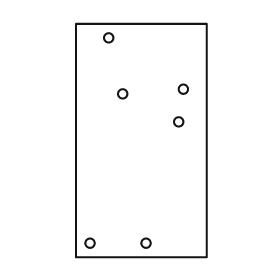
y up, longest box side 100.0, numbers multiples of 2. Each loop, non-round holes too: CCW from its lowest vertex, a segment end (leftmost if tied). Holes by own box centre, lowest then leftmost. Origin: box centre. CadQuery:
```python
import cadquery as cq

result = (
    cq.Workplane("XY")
    .moveTo(-28.0, -50.0)
    .lineTo(28.0, -50.0)
    .lineTo(28.0, 50.0)
    .lineTo(-28.0, 50.0)
    .close()
    .moveTo(-22.0, -44.0)
    .circle(2.0)
    .moveTo(2.0, -44.0)
    .circle(2.0)
    .moveTo(16.0, 8.0)
    .circle(2.0)
    .moveTo(-8.0, 20.0)
    .circle(2.0)
    .moveTo(18.0, 22.0)
    .circle(2.0)
    .moveTo(-14.0, 44.0)
    .circle(2.0)
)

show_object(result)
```